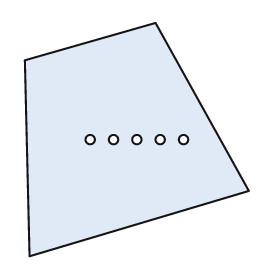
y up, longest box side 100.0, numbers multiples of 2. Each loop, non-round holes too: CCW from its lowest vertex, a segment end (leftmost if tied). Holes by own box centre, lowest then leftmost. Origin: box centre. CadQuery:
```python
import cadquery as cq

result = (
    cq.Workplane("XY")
    .moveTo(-46.0, -50.0)
    .lineTo(48.0, -22.0)
    .lineTo(8.0, 50.0)
    .lineTo(-48.0, 34.0)
    .close()
    .moveTo(-20.0, 0.0)
    .circle(2.0)
    .moveTo(-10.0, 0.0)
    .circle(2.0)
    .moveTo(0.0, 0.0)
    .circle(2.0)
    .moveTo(10.0, 0.0)
    .circle(2.0)
    .moveTo(20.0, 0.0)
    .circle(2.0)
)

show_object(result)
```